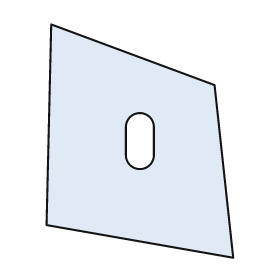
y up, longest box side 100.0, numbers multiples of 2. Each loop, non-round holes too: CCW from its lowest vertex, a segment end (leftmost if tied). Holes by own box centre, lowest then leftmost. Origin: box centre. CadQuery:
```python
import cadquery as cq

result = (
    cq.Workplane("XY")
    .moveTo(40.0, -50.0)
    .lineTo(32.0, 24.0)
    .lineTo(-38.0, 50.0)
    .lineTo(-40.0, -36.0)
    .close()
    .moveTo(-6.0, -6.0)
    .threePointArc((0.0, -12.0), (6.0, -6.0))
    .lineTo(6.0, 6.0)
    .threePointArc((0.0, 12.0), (-6.0, 6.0))
    .close()
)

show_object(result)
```